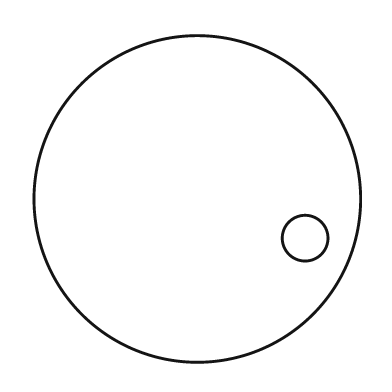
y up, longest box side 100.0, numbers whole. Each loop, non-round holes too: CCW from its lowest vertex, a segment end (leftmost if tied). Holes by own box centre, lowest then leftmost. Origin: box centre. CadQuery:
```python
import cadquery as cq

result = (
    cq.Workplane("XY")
    .moveTo(0.0, 0.0)
    .circle(50.0)
    .moveTo(33.0, -12.0)
    .circle(7.0)
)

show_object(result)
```